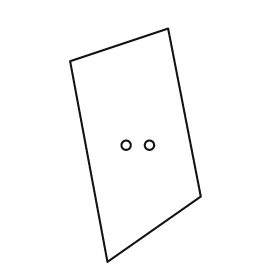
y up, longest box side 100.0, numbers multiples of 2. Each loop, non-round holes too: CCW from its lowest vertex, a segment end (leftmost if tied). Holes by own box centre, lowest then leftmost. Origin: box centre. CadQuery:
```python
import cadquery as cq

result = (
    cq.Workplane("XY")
    .moveTo(-12.0, -50.0)
    .lineTo(28.0, -22.0)
    .lineTo(14.0, 50.0)
    .lineTo(-28.0, 36.0)
    .close()
    .moveTo(-4.0, 0.0)
    .circle(2.0)
    .moveTo(6.0, 0.0)
    .circle(2.0)
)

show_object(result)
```